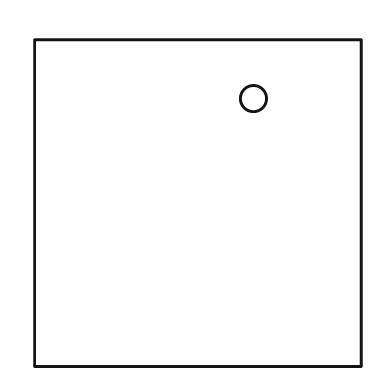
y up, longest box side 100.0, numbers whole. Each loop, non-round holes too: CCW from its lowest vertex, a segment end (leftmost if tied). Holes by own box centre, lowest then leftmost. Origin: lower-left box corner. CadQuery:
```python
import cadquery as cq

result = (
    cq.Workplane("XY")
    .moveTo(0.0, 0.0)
    .lineTo(100.0, 0.0)
    .lineTo(100.0, 100.0)
    .lineTo(0.0, 100.0)
    .close()
    .moveTo(67.0, 82.0)
    .circle(4.0)
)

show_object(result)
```